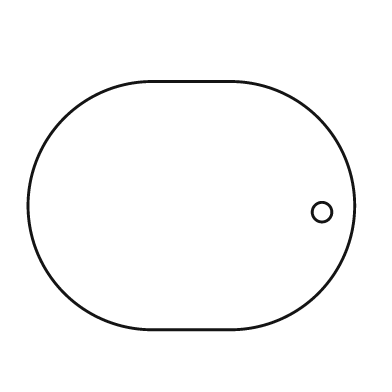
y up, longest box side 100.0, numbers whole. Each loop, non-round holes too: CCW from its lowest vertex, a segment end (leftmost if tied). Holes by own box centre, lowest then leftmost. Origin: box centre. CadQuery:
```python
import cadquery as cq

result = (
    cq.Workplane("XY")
    .moveTo(-12.0, -38.0)
    .lineTo(12.0, -38.0)
    .threePointArc((50.0, 0.0), (12.0, 38.0))
    .lineTo(-12.0, 38.0)
    .threePointArc((-50.0, 0.0), (-12.0, -38.0))
    .close()
    .moveTo(40.0, -2.0)
    .circle(3.0)
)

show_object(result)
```